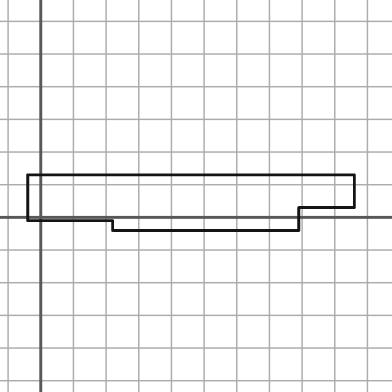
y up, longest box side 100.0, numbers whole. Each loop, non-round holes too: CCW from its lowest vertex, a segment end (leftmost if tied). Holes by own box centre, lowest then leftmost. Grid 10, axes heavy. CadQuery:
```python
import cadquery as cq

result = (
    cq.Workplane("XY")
    .moveTo(22.0, -4.0)
    .lineTo(79.0, -4.0)
    .lineTo(79.0, 3.0)
    .lineTo(96.0, 3.0)
    .lineTo(96.0, 13.0)
    .lineTo(-4.0, 13.0)
    .lineTo(-4.0, -1.0)
    .lineTo(22.0, -1.0)
    .close()
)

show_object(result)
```